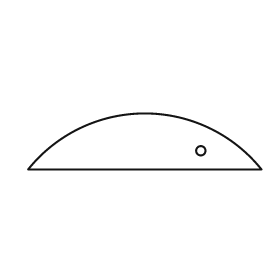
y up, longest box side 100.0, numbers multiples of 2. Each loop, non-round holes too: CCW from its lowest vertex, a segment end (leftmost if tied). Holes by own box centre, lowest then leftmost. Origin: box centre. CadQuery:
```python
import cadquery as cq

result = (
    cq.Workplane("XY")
    .moveTo(-50.0, -12.0)
    .lineTo(50.0, -12.0)
    .threePointArc((0.0, 12.0), (-50.0, -12.0))
    .close()
    .moveTo(24.0, -4.0)
    .circle(2.0)
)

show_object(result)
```